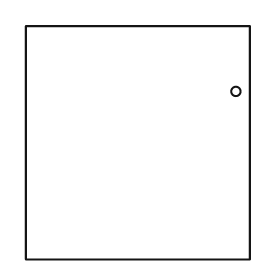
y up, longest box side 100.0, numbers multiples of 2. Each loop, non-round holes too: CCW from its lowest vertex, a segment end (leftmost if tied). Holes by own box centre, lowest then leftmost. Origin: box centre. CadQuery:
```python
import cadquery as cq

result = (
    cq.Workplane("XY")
    .moveTo(-48.0, -50.0)
    .lineTo(48.0, -50.0)
    .lineTo(48.0, 50.0)
    .lineTo(-48.0, 50.0)
    .close()
    .moveTo(42.0, 22.0)
    .circle(2.0)
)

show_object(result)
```